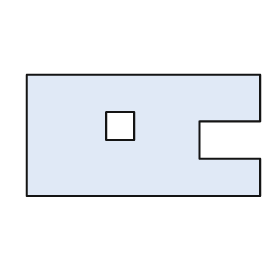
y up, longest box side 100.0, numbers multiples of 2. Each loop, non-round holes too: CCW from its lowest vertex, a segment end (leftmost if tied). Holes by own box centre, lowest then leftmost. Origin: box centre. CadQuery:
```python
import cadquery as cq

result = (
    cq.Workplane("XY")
    .moveTo(-50.0, -26.0)
    .lineTo(50.0, -26.0)
    .lineTo(50.0, -10.0)
    .lineTo(24.0, -10.0)
    .lineTo(24.0, 6.0)
    .lineTo(50.0, 6.0)
    .lineTo(50.0, 26.0)
    .lineTo(-50.0, 26.0)
    .close()
    .moveTo(-16.0, -2.0)
    .lineTo(-4.0, -2.0)
    .lineTo(-4.0, 10.0)
    .lineTo(-16.0, 10.0)
    .close()
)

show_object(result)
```